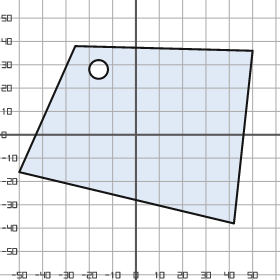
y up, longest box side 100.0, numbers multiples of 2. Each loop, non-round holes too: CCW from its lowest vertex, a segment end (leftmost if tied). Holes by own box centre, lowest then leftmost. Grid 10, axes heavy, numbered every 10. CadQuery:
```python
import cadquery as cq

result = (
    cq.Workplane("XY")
    .moveTo(42.0, -38.0)
    .lineTo(50.0, 36.0)
    .lineTo(-26.0, 38.0)
    .lineTo(-50.0, -16.0)
    .close()
    .moveTo(-16.0, 28.0)
    .circle(4.0)
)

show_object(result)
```